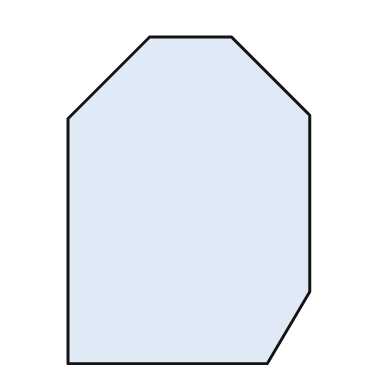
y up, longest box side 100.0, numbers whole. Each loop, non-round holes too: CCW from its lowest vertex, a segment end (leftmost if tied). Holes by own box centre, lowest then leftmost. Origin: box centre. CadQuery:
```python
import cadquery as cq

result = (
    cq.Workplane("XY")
    .moveTo(-37.0, -50.0)
    .lineTo(24.0, -50.0)
    .lineTo(37.0, -28.0)
    .lineTo(37.0, 26.0)
    .lineTo(13.0, 50.0)
    .lineTo(-12.0, 50.0)
    .lineTo(-37.0, 25.0)
    .close()
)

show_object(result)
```